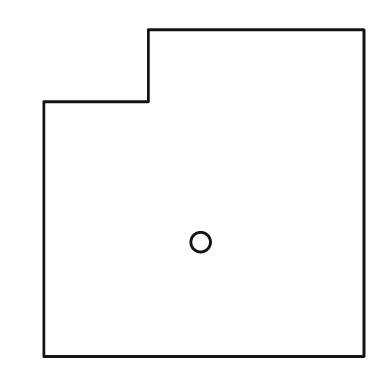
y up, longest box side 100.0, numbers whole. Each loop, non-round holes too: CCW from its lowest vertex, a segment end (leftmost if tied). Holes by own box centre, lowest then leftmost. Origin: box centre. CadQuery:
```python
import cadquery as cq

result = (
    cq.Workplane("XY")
    .moveTo(-49.0, -50.0)
    .lineTo(49.0, -50.0)
    .lineTo(49.0, 50.0)
    .lineTo(-17.0, 50.0)
    .lineTo(-17.0, 28.0)
    .lineTo(-49.0, 28.0)
    .close()
    .moveTo(-1.0, -15.0)
    .circle(3.0)
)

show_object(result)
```